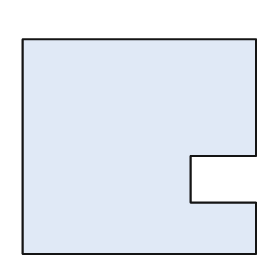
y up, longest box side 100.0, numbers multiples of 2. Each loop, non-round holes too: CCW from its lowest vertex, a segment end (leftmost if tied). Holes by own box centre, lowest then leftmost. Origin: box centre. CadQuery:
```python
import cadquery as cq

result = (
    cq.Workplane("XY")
    .moveTo(-50.0, -46.0)
    .lineTo(50.0, -46.0)
    .lineTo(50.0, -24.0)
    .lineTo(22.0, -24.0)
    .lineTo(22.0, -4.0)
    .lineTo(50.0, -4.0)
    .lineTo(50.0, 46.0)
    .lineTo(-50.0, 46.0)
    .close()
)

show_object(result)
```